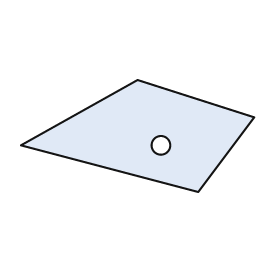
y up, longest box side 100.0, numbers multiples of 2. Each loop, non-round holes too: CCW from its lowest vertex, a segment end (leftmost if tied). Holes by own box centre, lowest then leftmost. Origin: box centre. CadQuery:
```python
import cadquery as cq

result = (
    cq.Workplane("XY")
    .moveTo(26.0, -24.0)
    .lineTo(50.0, 8.0)
    .lineTo(0.0, 24.0)
    .lineTo(-50.0, -4.0)
    .close()
    .moveTo(10.0, -4.0)
    .circle(4.0)
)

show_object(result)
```